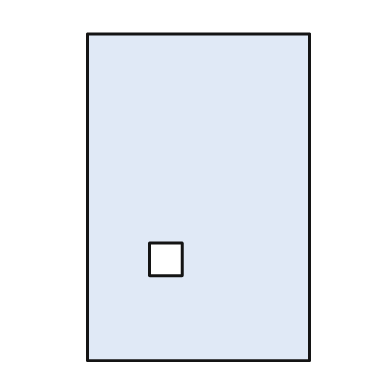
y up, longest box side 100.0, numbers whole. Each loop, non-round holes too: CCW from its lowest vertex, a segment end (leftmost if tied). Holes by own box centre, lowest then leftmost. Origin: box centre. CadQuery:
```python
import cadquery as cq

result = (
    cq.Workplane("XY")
    .moveTo(-34.0, -50.0)
    .lineTo(34.0, -50.0)
    .lineTo(34.0, 50.0)
    .lineTo(-34.0, 50.0)
    .close()
    .moveTo(-15.0, -24.0)
    .lineTo(-5.0, -24.0)
    .lineTo(-5.0, -14.0)
    .lineTo(-15.0, -14.0)
    .close()
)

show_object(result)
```